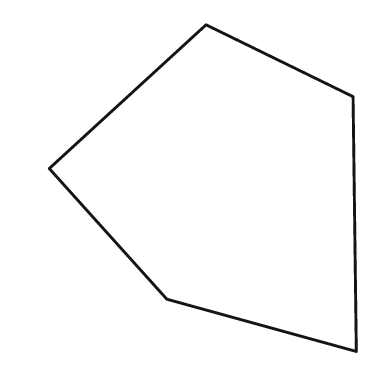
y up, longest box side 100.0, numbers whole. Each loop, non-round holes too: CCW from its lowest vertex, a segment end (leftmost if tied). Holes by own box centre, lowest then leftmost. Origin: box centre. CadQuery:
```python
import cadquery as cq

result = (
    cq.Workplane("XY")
    .moveTo(47.0, -50.0)
    .lineTo(46.0, 28.0)
    .lineTo(1.0, 50.0)
    .lineTo(-47.0, 6.0)
    .lineTo(-11.0, -34.0)
    .close()
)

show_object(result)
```